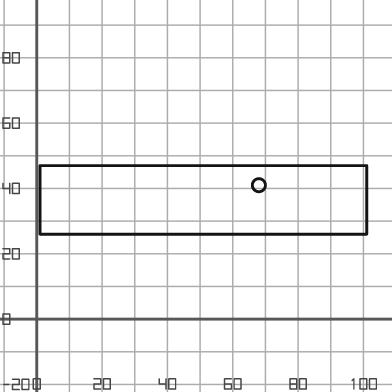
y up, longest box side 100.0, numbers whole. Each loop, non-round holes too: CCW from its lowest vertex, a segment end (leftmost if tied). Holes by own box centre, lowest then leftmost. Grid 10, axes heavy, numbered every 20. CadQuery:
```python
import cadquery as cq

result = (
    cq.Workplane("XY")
    .moveTo(1.0, 26.0)
    .lineTo(101.0, 26.0)
    .lineTo(101.0, 47.0)
    .lineTo(1.0, 47.0)
    .close()
    .moveTo(68.0, 41.0)
    .circle(2.0)
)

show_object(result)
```